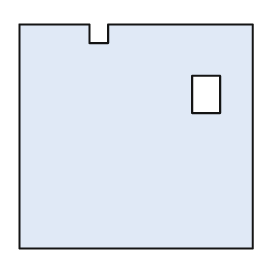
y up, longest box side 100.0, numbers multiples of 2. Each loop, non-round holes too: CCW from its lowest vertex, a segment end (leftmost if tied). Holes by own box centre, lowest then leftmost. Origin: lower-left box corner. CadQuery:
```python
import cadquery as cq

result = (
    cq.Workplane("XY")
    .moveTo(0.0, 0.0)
    .lineTo(100.0, 0.0)
    .lineTo(100.0, 96.0)
    .lineTo(38.0, 96.0)
    .lineTo(38.0, 88.0)
    .lineTo(30.0, 88.0)
    .lineTo(30.0, 96.0)
    .lineTo(0.0, 96.0)
    .close()
    .moveTo(74.0, 58.0)
    .lineTo(86.0, 58.0)
    .lineTo(86.0, 74.0)
    .lineTo(74.0, 74.0)
    .close()
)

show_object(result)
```